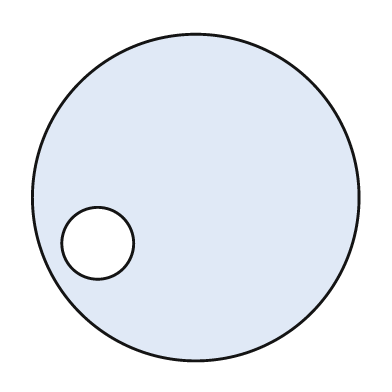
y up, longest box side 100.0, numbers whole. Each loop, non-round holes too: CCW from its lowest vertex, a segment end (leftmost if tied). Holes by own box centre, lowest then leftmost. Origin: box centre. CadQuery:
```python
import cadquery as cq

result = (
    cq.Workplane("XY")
    .moveTo(0.0, 0.0)
    .circle(50.0)
    .moveTo(-30.0, -14.0)
    .circle(11.0)
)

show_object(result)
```